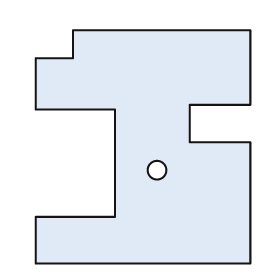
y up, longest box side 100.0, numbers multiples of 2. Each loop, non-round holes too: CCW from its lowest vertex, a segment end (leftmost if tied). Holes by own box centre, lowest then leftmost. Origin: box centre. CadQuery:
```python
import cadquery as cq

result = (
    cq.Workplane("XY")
    .moveTo(-46.0, -50.0)
    .lineTo(46.0, -50.0)
    .lineTo(46.0, 2.0)
    .lineTo(20.0, 2.0)
    .lineTo(20.0, 18.0)
    .lineTo(46.0, 18.0)
    .lineTo(46.0, 50.0)
    .lineTo(-30.0, 50.0)
    .lineTo(-30.0, 38.0)
    .lineTo(-46.0, 38.0)
    .lineTo(-46.0, 16.0)
    .lineTo(-12.0, 16.0)
    .lineTo(-12.0, -30.0)
    .lineTo(-46.0, -30.0)
    .close()
    .moveTo(6.0, -10.0)
    .circle(4.0)
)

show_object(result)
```